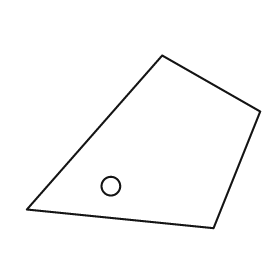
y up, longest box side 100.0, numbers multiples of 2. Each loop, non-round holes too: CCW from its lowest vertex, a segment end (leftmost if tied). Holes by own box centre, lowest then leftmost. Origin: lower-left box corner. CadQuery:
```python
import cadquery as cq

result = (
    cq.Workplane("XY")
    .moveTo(80.0, 0.0)
    .lineTo(100.0, 50.0)
    .lineTo(58.0, 74.0)
    .lineTo(0.0, 8.0)
    .close()
    .moveTo(36.0, 18.0)
    .circle(4.0)
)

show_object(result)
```